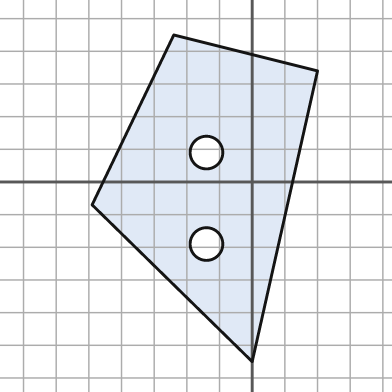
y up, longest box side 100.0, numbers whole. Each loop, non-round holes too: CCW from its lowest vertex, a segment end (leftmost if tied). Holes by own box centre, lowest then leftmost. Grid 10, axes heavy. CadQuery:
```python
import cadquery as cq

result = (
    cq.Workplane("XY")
    .moveTo(0.0, -55.0)
    .lineTo(20.0, 34.0)
    .lineTo(-24.0, 45.0)
    .lineTo(-49.0, -7.0)
    .close()
    .moveTo(-14.0, -19.0)
    .circle(5.0)
    .moveTo(-14.0, 9.0)
    .circle(5.0)
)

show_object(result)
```